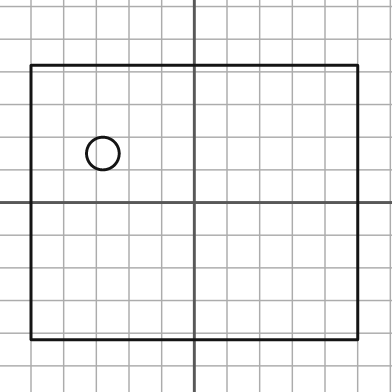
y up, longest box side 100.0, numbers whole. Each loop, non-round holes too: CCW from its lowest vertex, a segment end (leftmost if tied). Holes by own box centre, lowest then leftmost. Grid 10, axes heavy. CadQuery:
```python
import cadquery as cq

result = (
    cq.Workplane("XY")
    .moveTo(-50.0, -42.0)
    .lineTo(50.0, -42.0)
    .lineTo(50.0, 42.0)
    .lineTo(-50.0, 42.0)
    .close()
    .moveTo(-28.0, 15.0)
    .circle(5.0)
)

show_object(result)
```